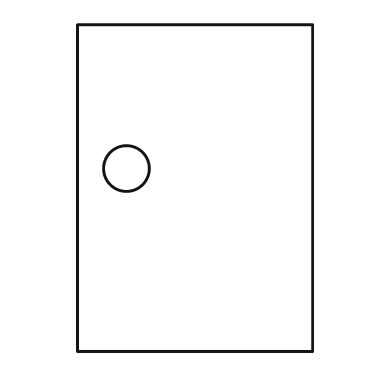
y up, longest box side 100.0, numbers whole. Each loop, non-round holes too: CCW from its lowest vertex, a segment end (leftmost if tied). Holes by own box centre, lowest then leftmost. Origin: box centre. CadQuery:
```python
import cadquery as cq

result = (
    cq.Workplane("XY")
    .moveTo(-36.0, -50.0)
    .lineTo(36.0, -50.0)
    .lineTo(36.0, 50.0)
    .lineTo(-36.0, 50.0)
    .close()
    .moveTo(-21.0, 6.0)
    .circle(7.0)
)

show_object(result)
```